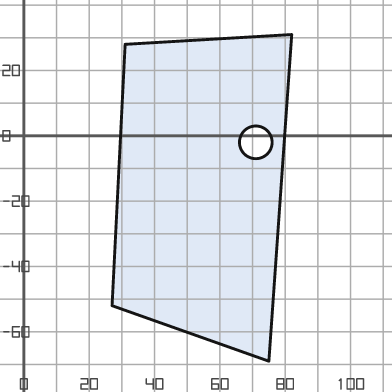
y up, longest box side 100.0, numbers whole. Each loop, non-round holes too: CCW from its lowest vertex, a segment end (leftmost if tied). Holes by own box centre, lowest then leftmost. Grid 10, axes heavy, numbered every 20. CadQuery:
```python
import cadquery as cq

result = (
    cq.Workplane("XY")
    .moveTo(75.0, -69.0)
    .lineTo(82.0, 31.0)
    .lineTo(31.0, 28.0)
    .lineTo(27.0, -52.0)
    .close()
    .moveTo(71.0, -2.0)
    .circle(5.0)
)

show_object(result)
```